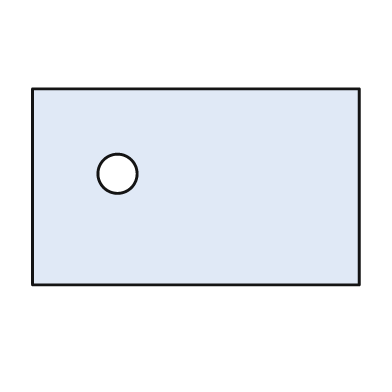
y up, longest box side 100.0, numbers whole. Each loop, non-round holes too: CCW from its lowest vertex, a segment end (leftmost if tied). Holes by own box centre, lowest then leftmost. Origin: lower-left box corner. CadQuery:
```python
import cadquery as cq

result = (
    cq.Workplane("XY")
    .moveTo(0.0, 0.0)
    .lineTo(100.0, 0.0)
    .lineTo(100.0, 60.0)
    .lineTo(0.0, 60.0)
    .close()
    .moveTo(26.0, 34.0)
    .circle(6.0)
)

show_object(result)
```